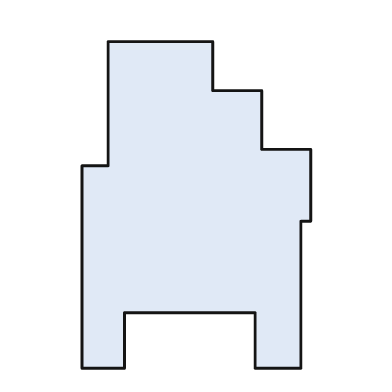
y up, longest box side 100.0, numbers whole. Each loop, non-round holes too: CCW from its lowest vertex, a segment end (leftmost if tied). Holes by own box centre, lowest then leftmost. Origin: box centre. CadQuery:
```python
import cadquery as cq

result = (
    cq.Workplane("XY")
    .moveTo(-35.0, -50.0)
    .lineTo(-22.0, -50.0)
    .lineTo(-22.0, -33.0)
    .lineTo(18.0, -33.0)
    .lineTo(18.0, -50.0)
    .lineTo(32.0, -50.0)
    .lineTo(32.0, -5.0)
    .lineTo(35.0, -5.0)
    .lineTo(35.0, 17.0)
    .lineTo(20.0, 17.0)
    .lineTo(20.0, 35.0)
    .lineTo(5.0, 35.0)
    .lineTo(5.0, 50.0)
    .lineTo(-27.0, 50.0)
    .lineTo(-27.0, 12.0)
    .lineTo(-35.0, 12.0)
    .close()
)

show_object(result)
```